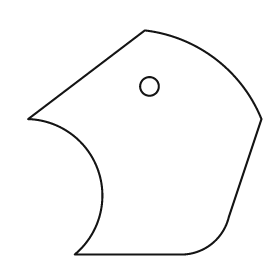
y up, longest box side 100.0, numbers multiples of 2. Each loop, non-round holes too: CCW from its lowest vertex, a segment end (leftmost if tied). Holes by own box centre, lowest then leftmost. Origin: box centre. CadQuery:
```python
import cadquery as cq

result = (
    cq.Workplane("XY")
    .moveTo(-30.0, -48.0)
    .lineTo(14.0, -48.0)
    .threePointArc((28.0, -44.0), (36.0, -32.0))
    .lineTo(50.0, 10.0)
    .threePointArc((30.0, 36.0), (0.0, 48.0))
    .lineTo(-50.0, 10.0)
    .threePointArc((-20.0, -12.0), (-30.0, -48.0))
    .close()
    .moveTo(2.0, 24.0)
    .circle(4.0)
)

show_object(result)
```